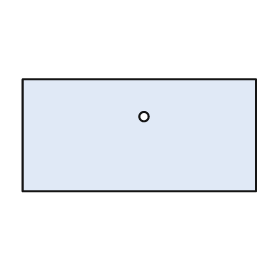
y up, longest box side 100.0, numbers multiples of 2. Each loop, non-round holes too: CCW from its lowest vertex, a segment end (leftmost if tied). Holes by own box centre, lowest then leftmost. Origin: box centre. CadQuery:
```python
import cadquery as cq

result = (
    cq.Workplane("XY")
    .moveTo(-50.0, -24.0)
    .lineTo(50.0, -24.0)
    .lineTo(50.0, 24.0)
    .lineTo(-50.0, 24.0)
    .close()
    .moveTo(2.0, 8.0)
    .circle(2.0)
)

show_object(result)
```